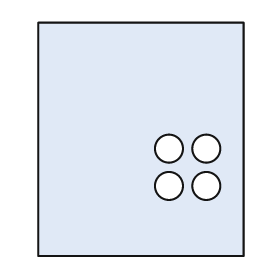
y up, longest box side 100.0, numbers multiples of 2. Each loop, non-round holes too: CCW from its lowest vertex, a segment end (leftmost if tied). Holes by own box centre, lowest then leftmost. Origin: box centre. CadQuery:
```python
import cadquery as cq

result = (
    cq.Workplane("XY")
    .moveTo(-44.0, -50.0)
    .lineTo(44.0, -50.0)
    .lineTo(44.0, 50.0)
    .lineTo(-44.0, 50.0)
    .close()
    .moveTo(12.0, -20.0)
    .circle(6.0)
    .moveTo(28.0, -20.0)
    .circle(6.0)
    .moveTo(12.0, -4.0)
    .circle(6.0)
    .moveTo(28.0, -4.0)
    .circle(6.0)
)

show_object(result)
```